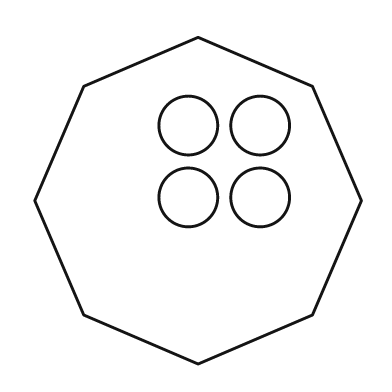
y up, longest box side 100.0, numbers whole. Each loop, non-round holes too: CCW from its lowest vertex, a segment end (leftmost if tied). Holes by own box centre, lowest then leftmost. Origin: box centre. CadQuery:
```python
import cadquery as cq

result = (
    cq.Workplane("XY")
    .moveTo(0.0, -50.0)
    .lineTo(35.0, -35.0)
    .lineTo(50.0, 0.0)
    .lineTo(35.0, 35.0)
    .lineTo(0.0, 50.0)
    .lineTo(-35.0, 35.0)
    .lineTo(-50.0, 0.0)
    .lineTo(-35.0, -35.0)
    .close()
    .moveTo(-3.0, 1.0)
    .circle(9.0)
    .moveTo(19.0, 1.0)
    .circle(9.0)
    .moveTo(-3.0, 23.0)
    .circle(9.0)
    .moveTo(19.0, 23.0)
    .circle(9.0)
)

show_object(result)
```